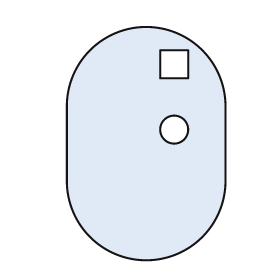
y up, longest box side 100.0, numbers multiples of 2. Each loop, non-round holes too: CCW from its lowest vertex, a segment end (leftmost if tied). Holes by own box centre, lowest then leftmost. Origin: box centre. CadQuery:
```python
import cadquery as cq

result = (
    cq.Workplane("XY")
    .moveTo(-34.0, -16.0)
    .threePointArc((0.0, -50.0), (34.0, -16.0))
    .lineTo(34.0, 16.0)
    .threePointArc((0.0, 50.0), (-34.0, 16.0))
    .close()
    .moveTo(12.0, 6.0)
    .circle(6.0)
    .moveTo(6.0, 28.0)
    .lineTo(18.0, 28.0)
    .lineTo(18.0, 40.0)
    .lineTo(6.0, 40.0)
    .close()
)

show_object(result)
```